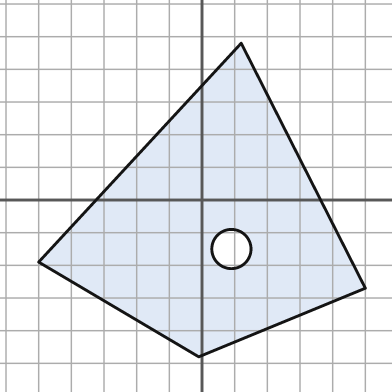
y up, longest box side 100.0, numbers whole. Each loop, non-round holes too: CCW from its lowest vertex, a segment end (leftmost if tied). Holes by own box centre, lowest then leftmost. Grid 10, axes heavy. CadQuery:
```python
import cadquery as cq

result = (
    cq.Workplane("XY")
    .moveTo(-1.0, -48.0)
    .lineTo(50.0, -27.0)
    .lineTo(12.0, 48.0)
    .lineTo(-50.0, -19.0)
    .close()
    .moveTo(9.0, -15.0)
    .circle(6.0)
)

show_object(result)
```